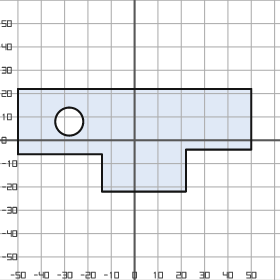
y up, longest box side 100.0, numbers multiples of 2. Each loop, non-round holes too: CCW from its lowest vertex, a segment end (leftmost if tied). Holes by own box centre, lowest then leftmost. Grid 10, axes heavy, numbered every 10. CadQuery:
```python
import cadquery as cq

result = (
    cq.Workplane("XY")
    .moveTo(-14.0, -22.0)
    .lineTo(22.0, -22.0)
    .lineTo(22.0, -4.0)
    .lineTo(50.0, -4.0)
    .lineTo(50.0, 22.0)
    .lineTo(-50.0, 22.0)
    .lineTo(-50.0, -6.0)
    .lineTo(-14.0, -6.0)
    .close()
    .moveTo(-28.0, 8.0)
    .circle(6.0)
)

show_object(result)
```